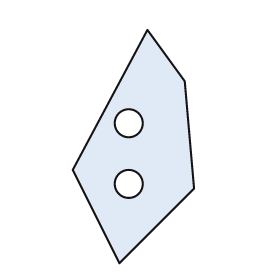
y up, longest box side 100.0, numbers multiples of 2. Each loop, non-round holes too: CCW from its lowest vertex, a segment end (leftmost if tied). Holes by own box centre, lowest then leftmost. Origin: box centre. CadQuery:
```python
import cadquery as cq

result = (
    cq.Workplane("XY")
    .moveTo(-6.0, -50.0)
    .lineTo(26.0, -18.0)
    .lineTo(22.0, 28.0)
    .lineTo(6.0, 50.0)
    .lineTo(-26.0, -10.0)
    .close()
    .moveTo(-2.0, -16.0)
    .circle(6.0)
    .moveTo(-2.0, 10.0)
    .circle(6.0)
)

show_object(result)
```